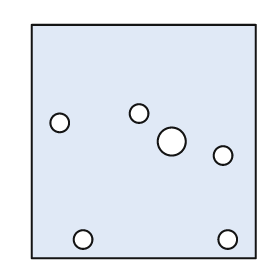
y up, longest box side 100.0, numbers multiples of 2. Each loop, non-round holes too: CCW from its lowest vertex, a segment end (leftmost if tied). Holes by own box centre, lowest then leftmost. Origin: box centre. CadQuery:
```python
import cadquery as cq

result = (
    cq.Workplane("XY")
    .moveTo(-48.0, -50.0)
    .lineTo(48.0, -50.0)
    .lineTo(48.0, 50.0)
    .lineTo(-48.0, 50.0)
    .close()
    .moveTo(-26.0, -42.0)
    .circle(4.0)
    .moveTo(36.0, -42.0)
    .circle(4.0)
    .moveTo(34.0, -6.0)
    .circle(4.0)
    .moveTo(12.0, 0.0)
    .circle(6.0)
    .moveTo(-36.0, 8.0)
    .circle(4.0)
    .moveTo(-2.0, 12.0)
    .circle(4.0)
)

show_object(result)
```